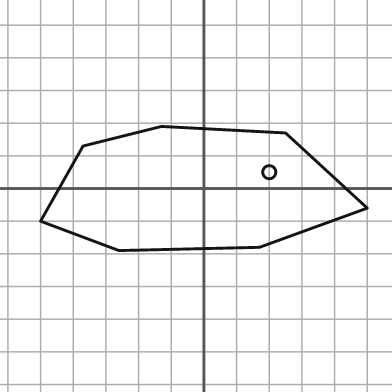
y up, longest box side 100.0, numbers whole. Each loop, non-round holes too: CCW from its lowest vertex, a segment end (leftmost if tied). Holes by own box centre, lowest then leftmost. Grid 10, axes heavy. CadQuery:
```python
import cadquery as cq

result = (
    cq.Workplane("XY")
    .moveTo(-26.0, -19.0)
    .lineTo(17.0, -18.0)
    .lineTo(50.0, -6.0)
    .lineTo(25.0, 17.0)
    .lineTo(-13.0, 19.0)
    .lineTo(-37.0, 13.0)
    .lineTo(-50.0, -10.0)
    .close()
    .moveTo(20.0, 5.0)
    .circle(2.0)
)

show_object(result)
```